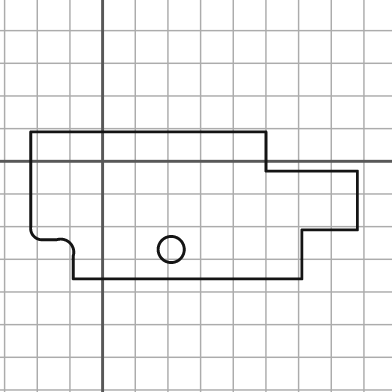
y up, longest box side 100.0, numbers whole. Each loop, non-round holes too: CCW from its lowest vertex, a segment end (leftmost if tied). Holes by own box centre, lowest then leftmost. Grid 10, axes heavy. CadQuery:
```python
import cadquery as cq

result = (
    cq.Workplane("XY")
    .moveTo(-9.0, -36.0)
    .lineTo(61.0, -36.0)
    .lineTo(61.0, -21.0)
    .lineTo(78.0, -21.0)
    .lineTo(78.0, -3.0)
    .lineTo(50.0, -3.0)
    .lineTo(50.0, 9.0)
    .lineTo(-22.0, 9.0)
    .lineTo(-22.0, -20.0)
    .threePointArc((-21.0, -23.0), (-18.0, -24.0))
    .lineTo(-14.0, -24.0)
    .threePointArc((-10.0, -25.0), (-9.0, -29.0))
    .close()
    .moveTo(21.0, -27.0)
    .circle(4.0)
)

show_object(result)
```